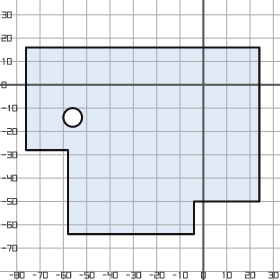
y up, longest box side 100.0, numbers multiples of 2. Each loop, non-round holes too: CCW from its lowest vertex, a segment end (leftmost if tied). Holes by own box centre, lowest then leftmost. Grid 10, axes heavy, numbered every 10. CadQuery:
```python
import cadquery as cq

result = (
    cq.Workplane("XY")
    .moveTo(-58.0, -64.0)
    .lineTo(-4.0, -64.0)
    .lineTo(-4.0, -50.0)
    .lineTo(24.0, -50.0)
    .lineTo(24.0, 16.0)
    .lineTo(-76.0, 16.0)
    .lineTo(-76.0, -28.0)
    .lineTo(-58.0, -28.0)
    .close()
    .moveTo(-56.0, -14.0)
    .circle(4.0)
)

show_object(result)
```